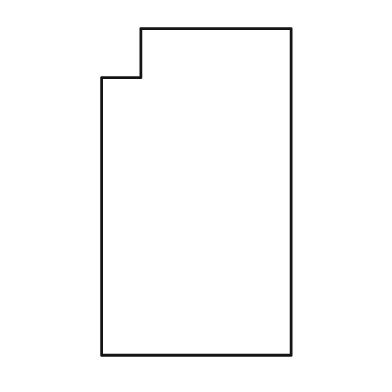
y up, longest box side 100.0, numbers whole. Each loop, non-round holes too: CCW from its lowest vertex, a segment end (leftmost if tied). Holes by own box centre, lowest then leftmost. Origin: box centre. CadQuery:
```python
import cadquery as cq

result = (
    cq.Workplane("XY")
    .moveTo(-29.0, -50.0)
    .lineTo(29.0, -50.0)
    .lineTo(29.0, 50.0)
    .lineTo(-17.0, 50.0)
    .lineTo(-17.0, 35.0)
    .lineTo(-29.0, 35.0)
    .close()
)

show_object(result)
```